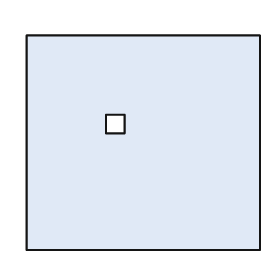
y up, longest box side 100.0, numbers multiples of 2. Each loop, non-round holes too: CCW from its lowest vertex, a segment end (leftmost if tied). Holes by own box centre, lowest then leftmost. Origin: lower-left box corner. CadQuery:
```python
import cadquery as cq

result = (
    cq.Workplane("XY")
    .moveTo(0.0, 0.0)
    .lineTo(100.0, 0.0)
    .lineTo(100.0, 92.0)
    .lineTo(0.0, 92.0)
    .close()
    .moveTo(34.0, 50.0)
    .lineTo(42.0, 50.0)
    .lineTo(42.0, 58.0)
    .lineTo(34.0, 58.0)
    .close()
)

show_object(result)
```